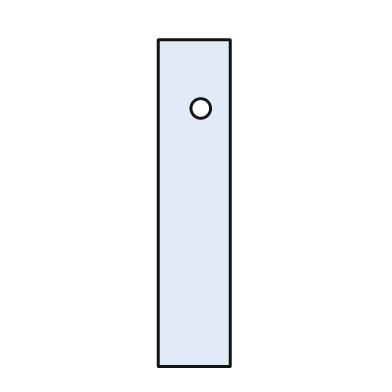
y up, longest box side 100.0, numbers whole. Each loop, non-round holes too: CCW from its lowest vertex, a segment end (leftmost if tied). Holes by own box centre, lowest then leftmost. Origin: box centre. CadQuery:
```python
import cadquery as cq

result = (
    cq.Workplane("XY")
    .moveTo(-11.0, -50.0)
    .lineTo(11.0, -50.0)
    .lineTo(11.0, 50.0)
    .lineTo(-11.0, 50.0)
    .close()
    .moveTo(2.0, 29.0)
    .circle(3.0)
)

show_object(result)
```